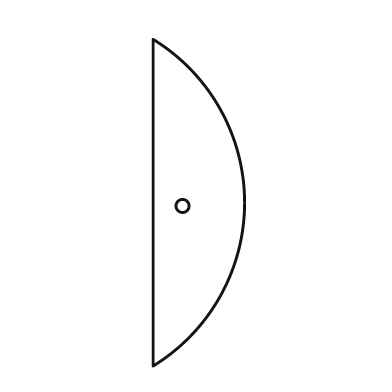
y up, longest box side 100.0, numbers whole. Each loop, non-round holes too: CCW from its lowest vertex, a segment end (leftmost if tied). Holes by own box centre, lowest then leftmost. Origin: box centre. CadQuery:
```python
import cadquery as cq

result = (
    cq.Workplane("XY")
    .moveTo(-14.0, -50.0)
    .threePointArc((14.0, 0.0), (-14.0, 50.0))
    .close()
    .moveTo(-5.0, -1.0)
    .circle(2.0)
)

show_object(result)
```